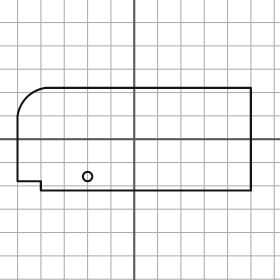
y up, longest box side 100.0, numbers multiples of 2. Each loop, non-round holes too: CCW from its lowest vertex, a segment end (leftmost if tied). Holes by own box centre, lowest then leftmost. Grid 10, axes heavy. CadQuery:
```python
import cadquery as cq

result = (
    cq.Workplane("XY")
    .moveTo(-40.0, -22.0)
    .lineTo(50.0, -22.0)
    .lineTo(50.0, 22.0)
    .lineTo(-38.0, 22.0)
    .threePointArc((-46.0, 18.0), (-50.0, 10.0))
    .lineTo(-50.0, -18.0)
    .lineTo(-40.0, -18.0)
    .close()
    .moveTo(-20.0, -16.0)
    .circle(2.0)
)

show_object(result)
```